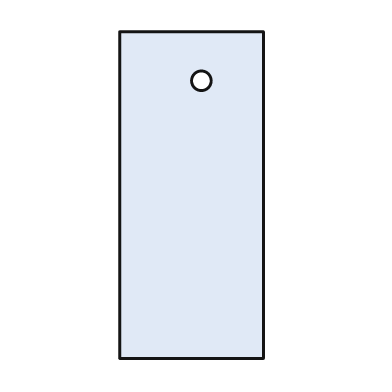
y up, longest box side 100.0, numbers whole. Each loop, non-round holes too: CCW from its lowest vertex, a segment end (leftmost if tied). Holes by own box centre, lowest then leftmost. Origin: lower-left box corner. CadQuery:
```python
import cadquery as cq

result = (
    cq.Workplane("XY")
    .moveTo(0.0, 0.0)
    .lineTo(44.0, 0.0)
    .lineTo(44.0, 100.0)
    .lineTo(0.0, 100.0)
    .close()
    .moveTo(25.0, 85.0)
    .circle(3.0)
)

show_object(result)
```